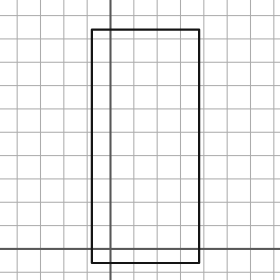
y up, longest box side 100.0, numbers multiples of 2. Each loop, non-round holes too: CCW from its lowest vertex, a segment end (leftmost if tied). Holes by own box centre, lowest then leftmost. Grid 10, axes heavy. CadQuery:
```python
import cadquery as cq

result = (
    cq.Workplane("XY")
    .moveTo(-8.0, -6.0)
    .lineTo(38.0, -6.0)
    .lineTo(38.0, 94.0)
    .lineTo(-8.0, 94.0)
    .close()
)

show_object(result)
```